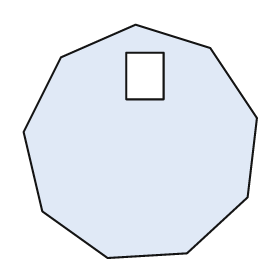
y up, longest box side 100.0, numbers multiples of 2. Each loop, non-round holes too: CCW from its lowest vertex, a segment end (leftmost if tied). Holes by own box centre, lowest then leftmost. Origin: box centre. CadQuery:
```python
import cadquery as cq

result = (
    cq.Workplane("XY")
    .moveTo(-14.0, -50.0)
    .lineTo(20.0, -48.0)
    .lineTo(46.0, -24.0)
    .lineTo(50.0, 10.0)
    .lineTo(30.0, 40.0)
    .lineTo(-2.0, 50.0)
    .lineTo(-34.0, 36.0)
    .lineTo(-50.0, 4.0)
    .lineTo(-42.0, -30.0)
    .close()
    .moveTo(-6.0, 18.0)
    .lineTo(10.0, 18.0)
    .lineTo(10.0, 38.0)
    .lineTo(-6.0, 38.0)
    .close()
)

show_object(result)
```